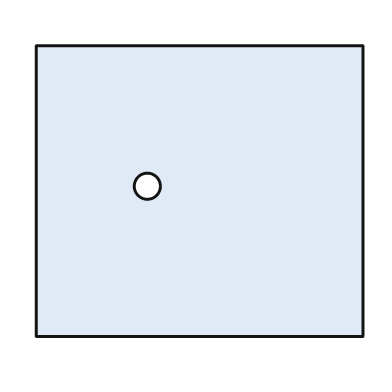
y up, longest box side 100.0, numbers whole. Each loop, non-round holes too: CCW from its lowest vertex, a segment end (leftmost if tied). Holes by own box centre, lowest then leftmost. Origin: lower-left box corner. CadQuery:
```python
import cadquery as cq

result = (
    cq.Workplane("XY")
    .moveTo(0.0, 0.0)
    .lineTo(100.0, 0.0)
    .lineTo(100.0, 89.0)
    .lineTo(0.0, 89.0)
    .close()
    .moveTo(34.0, 46.0)
    .circle(4.0)
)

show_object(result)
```